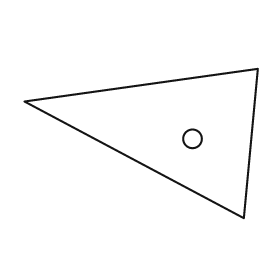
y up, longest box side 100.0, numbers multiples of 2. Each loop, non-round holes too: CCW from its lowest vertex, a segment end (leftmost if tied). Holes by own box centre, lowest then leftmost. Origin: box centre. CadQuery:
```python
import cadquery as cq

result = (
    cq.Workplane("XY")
    .moveTo(44.0, -32.0)
    .lineTo(50.0, 32.0)
    .lineTo(-50.0, 18.0)
    .close()
    .moveTo(22.0, 2.0)
    .circle(4.0)
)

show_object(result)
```